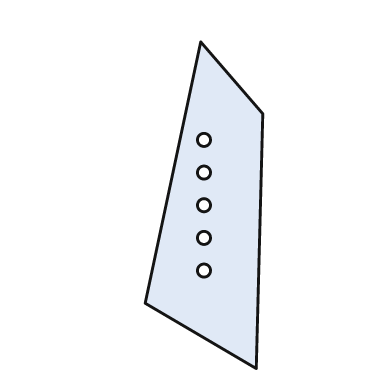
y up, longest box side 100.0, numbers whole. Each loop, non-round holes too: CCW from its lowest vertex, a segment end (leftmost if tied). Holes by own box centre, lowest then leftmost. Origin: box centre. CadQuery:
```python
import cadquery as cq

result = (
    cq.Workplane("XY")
    .moveTo(16.0, -50.0)
    .lineTo(18.0, 28.0)
    .lineTo(-1.0, 50.0)
    .lineTo(-18.0, -30.0)
    .close()
    .moveTo(0.0, -20.0)
    .circle(2.0)
    .moveTo(0.0, -10.0)
    .circle(2.0)
    .moveTo(0.0, 0.0)
    .circle(2.0)
    .moveTo(0.0, 10.0)
    .circle(2.0)
    .moveTo(0.0, 20.0)
    .circle(2.0)
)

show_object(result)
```